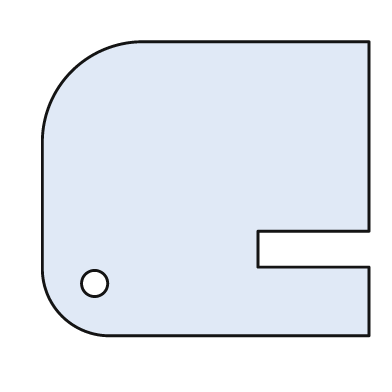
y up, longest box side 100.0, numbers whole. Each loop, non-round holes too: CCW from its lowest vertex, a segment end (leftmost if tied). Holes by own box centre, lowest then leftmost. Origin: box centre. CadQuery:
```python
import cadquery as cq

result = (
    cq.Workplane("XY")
    .moveTo(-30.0, -45.0)
    .lineTo(50.0, -45.0)
    .lineTo(50.0, -24.0)
    .lineTo(16.0, -24.0)
    .lineTo(16.0, -13.0)
    .lineTo(50.0, -13.0)
    .lineTo(50.0, 45.0)
    .lineTo(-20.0, 45.0)
    .threePointArc((-41.0, 36.0), (-50.0, 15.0))
    .lineTo(-50.0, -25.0)
    .threePointArc((-44.0, -39.0), (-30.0, -45.0))
    .close()
    .moveTo(-34.0, -29.0)
    .circle(4.0)
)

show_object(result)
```